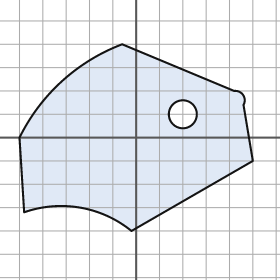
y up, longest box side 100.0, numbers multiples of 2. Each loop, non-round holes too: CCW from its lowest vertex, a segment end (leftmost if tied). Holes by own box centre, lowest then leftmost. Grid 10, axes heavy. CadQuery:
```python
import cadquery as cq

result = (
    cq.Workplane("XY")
    .moveTo(-2.0, -40.0)
    .lineTo(50.0, -10.0)
    .lineTo(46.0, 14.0)
    .threePointArc((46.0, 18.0), (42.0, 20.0))
    .lineTo(-6.0, 40.0)
    .threePointArc((-32.0, 24.0), (-50.0, 0.0))
    .lineTo(-48.0, -32.0)
    .threePointArc((-24.0, -30.0), (-2.0, -40.0))
    .close()
    .moveTo(20.0, 10.0)
    .circle(6.0)
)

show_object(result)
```